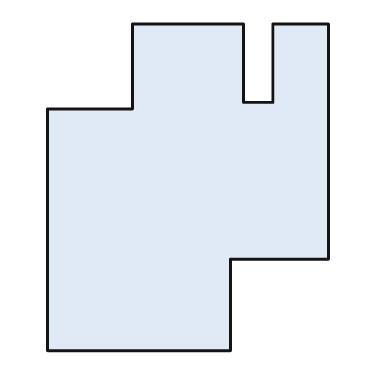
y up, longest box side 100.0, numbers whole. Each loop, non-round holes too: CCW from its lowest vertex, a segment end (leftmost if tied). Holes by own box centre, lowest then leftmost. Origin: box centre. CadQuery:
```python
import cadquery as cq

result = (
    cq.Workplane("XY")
    .moveTo(-43.0, -50.0)
    .lineTo(13.0, -50.0)
    .lineTo(13.0, -22.0)
    .lineTo(43.0, -22.0)
    .lineTo(43.0, 50.0)
    .lineTo(26.0, 50.0)
    .lineTo(26.0, 26.0)
    .lineTo(17.0, 26.0)
    .lineTo(17.0, 50.0)
    .lineTo(-17.0, 50.0)
    .lineTo(-17.0, 24.0)
    .lineTo(-43.0, 24.0)
    .close()
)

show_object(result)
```